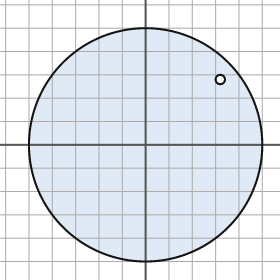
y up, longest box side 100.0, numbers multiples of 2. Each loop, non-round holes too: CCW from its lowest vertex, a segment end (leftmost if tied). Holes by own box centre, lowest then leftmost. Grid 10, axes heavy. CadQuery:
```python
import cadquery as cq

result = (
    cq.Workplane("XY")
    .moveTo(0.0, 0.0)
    .circle(50.0)
    .moveTo(32.0, 28.0)
    .circle(2.0)
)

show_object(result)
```